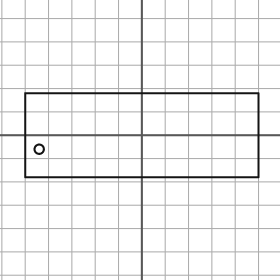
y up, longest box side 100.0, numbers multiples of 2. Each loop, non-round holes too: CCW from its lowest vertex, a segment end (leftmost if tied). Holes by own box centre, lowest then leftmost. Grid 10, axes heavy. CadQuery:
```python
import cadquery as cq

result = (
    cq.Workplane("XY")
    .moveTo(-50.0, -18.0)
    .lineTo(50.0, -18.0)
    .lineTo(50.0, 18.0)
    .lineTo(-50.0, 18.0)
    .close()
    .moveTo(-44.0, -6.0)
    .circle(2.0)
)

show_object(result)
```